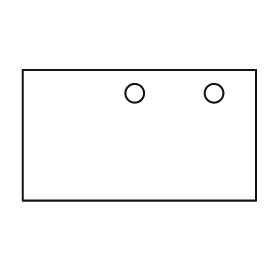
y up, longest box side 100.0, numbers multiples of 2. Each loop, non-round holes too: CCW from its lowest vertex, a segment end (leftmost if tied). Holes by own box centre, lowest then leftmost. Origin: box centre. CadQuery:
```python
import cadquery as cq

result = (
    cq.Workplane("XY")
    .moveTo(-50.0, -28.0)
    .lineTo(50.0, -28.0)
    .lineTo(50.0, 28.0)
    .lineTo(-50.0, 28.0)
    .close()
    .moveTo(-2.0, 18.0)
    .circle(4.0)
    .moveTo(32.0, 18.0)
    .circle(4.0)
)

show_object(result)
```